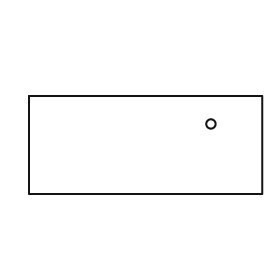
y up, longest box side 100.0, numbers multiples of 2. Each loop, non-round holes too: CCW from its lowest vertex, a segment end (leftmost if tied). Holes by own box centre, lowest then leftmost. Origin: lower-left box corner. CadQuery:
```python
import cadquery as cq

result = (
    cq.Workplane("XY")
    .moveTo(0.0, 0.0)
    .lineTo(100.0, 0.0)
    .lineTo(100.0, 42.0)
    .lineTo(0.0, 42.0)
    .close()
    .moveTo(78.0, 30.0)
    .circle(2.0)
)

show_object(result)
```